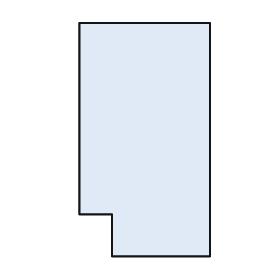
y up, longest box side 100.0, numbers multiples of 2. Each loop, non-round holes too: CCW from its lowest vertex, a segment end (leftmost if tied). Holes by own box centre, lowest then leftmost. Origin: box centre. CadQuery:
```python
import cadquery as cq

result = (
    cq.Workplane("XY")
    .moveTo(-14.0, -50.0)
    .lineTo(28.0, -50.0)
    .lineTo(28.0, 50.0)
    .lineTo(-28.0, 50.0)
    .lineTo(-28.0, -32.0)
    .lineTo(-14.0, -32.0)
    .close()
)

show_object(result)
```